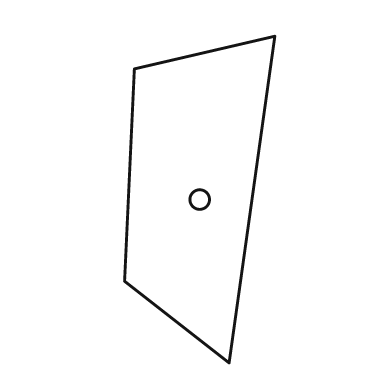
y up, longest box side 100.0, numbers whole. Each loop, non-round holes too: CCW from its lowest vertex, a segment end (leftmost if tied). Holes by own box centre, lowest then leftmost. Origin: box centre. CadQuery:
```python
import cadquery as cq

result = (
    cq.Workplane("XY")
    .moveTo(9.0, -50.0)
    .lineTo(23.0, 50.0)
    .lineTo(-20.0, 40.0)
    .lineTo(-23.0, -25.0)
    .close()
    .moveTo(0.0, 0.0)
    .circle(3.0)
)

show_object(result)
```